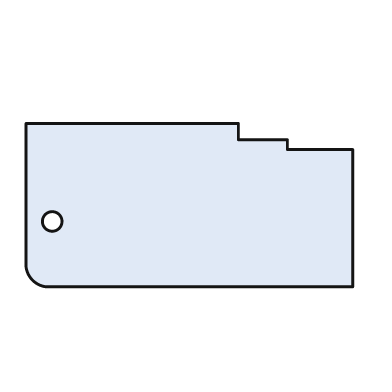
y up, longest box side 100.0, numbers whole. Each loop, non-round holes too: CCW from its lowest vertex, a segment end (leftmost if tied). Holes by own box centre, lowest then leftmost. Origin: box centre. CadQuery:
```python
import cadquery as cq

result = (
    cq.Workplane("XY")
    .moveTo(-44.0, -25.0)
    .lineTo(50.0, -25.0)
    .lineTo(50.0, 17.0)
    .lineTo(30.0, 17.0)
    .lineTo(30.0, 20.0)
    .lineTo(15.0, 20.0)
    .lineTo(15.0, 25.0)
    .lineTo(-50.0, 25.0)
    .lineTo(-50.0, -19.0)
    .threePointArc((-48.0, -23.0), (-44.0, -25.0))
    .close()
    .moveTo(-42.0, -5.0)
    .circle(3.0)
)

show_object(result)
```